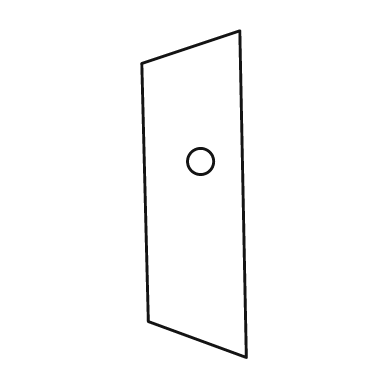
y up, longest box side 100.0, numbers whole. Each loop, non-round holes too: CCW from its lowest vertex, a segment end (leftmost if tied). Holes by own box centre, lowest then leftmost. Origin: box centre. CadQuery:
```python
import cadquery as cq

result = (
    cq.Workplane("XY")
    .moveTo(16.0, -50.0)
    .lineTo(14.0, 50.0)
    .lineTo(-16.0, 40.0)
    .lineTo(-14.0, -39.0)
    .close()
    .moveTo(2.0, 10.0)
    .circle(4.0)
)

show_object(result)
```